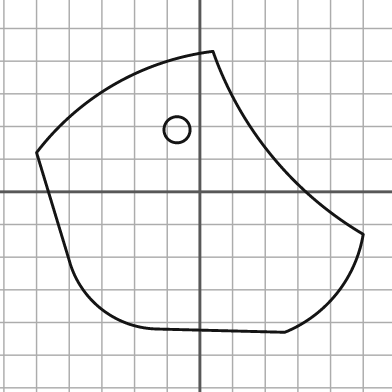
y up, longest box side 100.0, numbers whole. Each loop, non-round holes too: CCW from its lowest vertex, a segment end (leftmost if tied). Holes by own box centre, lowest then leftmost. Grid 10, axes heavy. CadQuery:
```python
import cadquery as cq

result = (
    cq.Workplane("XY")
    .moveTo(26.0, -43.0)
    .threePointArc((42.0, -31.0), (50.0, -13.0))
    .threePointArc((22.0, 11.0), (4.0, 43.0))
    .threePointArc((-26.0, 33.0), (-50.0, 12.0))
    .lineTo(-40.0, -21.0)
    .threePointArc((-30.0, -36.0), (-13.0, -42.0))
    .close()
    .moveTo(-7.0, 19.0)
    .circle(4.0)
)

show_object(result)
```